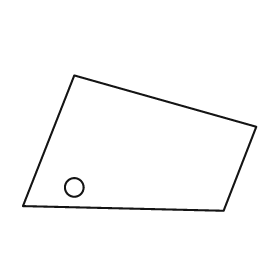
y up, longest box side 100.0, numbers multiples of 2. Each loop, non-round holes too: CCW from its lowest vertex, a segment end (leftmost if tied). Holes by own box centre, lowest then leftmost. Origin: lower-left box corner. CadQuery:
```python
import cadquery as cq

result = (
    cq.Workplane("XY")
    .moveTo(86.0, 0.0)
    .lineTo(100.0, 36.0)
    .lineTo(22.0, 58.0)
    .lineTo(0.0, 2.0)
    .close()
    .moveTo(22.0, 10.0)
    .circle(4.0)
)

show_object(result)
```